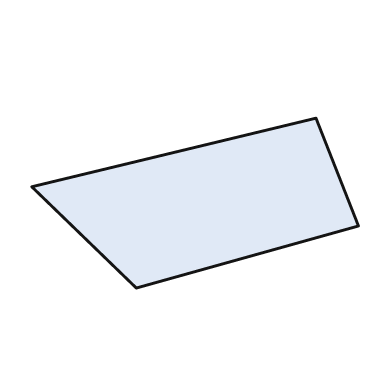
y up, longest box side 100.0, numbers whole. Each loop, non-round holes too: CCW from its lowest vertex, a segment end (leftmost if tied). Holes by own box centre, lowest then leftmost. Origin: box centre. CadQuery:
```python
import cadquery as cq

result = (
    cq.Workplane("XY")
    .moveTo(-18.0, -26.0)
    .lineTo(50.0, -7.0)
    .lineTo(37.0, 26.0)
    .lineTo(-50.0, 5.0)
    .close()
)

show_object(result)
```